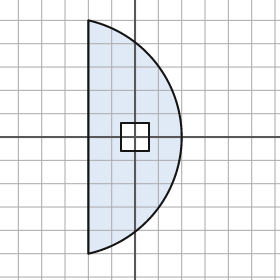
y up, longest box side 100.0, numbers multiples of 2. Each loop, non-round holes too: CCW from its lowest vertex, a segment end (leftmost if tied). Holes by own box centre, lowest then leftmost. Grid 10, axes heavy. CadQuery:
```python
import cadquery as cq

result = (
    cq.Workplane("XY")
    .moveTo(-20.0, -50.0)
    .threePointArc((20.0, 0.0), (-20.0, 50.0))
    .close()
    .moveTo(-6.0, -6.0)
    .lineTo(6.0, -6.0)
    .lineTo(6.0, 6.0)
    .lineTo(-6.0, 6.0)
    .close()
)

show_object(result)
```